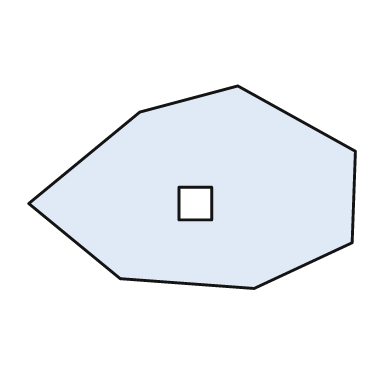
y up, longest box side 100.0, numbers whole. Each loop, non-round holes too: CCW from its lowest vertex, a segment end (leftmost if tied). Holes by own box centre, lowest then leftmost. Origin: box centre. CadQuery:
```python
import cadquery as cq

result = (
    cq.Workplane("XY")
    .moveTo(19.0, -31.0)
    .lineTo(49.0, -17.0)
    .lineTo(50.0, 11.0)
    .lineTo(14.0, 31.0)
    .lineTo(-16.0, 23.0)
    .lineTo(-50.0, -5.0)
    .lineTo(-22.0, -28.0)
    .close()
    .moveTo(-4.0, -10.0)
    .lineTo(6.0, -10.0)
    .lineTo(6.0, 0.0)
    .lineTo(-4.0, 0.0)
    .close()
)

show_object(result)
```